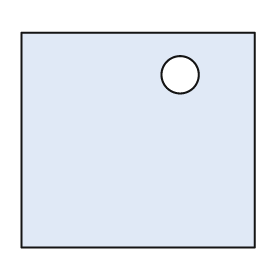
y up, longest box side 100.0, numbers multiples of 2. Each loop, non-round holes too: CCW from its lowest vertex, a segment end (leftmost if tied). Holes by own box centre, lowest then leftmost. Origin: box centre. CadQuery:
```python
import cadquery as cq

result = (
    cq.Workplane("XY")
    .moveTo(-50.0, -46.0)
    .lineTo(50.0, -46.0)
    .lineTo(50.0, 46.0)
    .lineTo(-50.0, 46.0)
    .close()
    .moveTo(18.0, 28.0)
    .circle(8.0)
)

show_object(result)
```